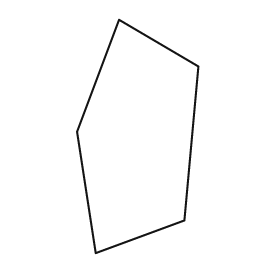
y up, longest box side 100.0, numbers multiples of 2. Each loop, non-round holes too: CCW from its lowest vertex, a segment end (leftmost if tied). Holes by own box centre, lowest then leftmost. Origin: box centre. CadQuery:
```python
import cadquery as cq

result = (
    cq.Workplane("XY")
    .moveTo(-18.0, -50.0)
    .lineTo(20.0, -36.0)
    .lineTo(26.0, 30.0)
    .lineTo(-8.0, 50.0)
    .lineTo(-26.0, 2.0)
    .close()
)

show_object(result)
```